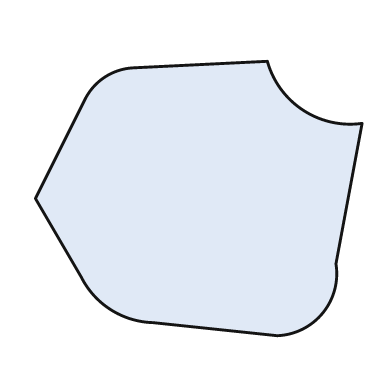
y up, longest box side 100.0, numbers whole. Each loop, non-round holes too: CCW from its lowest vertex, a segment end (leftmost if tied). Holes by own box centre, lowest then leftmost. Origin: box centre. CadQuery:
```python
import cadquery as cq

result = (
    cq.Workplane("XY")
    .moveTo(24.0, -42.0)
    .threePointArc((38.0, -35.0), (42.0, -20.0))
    .lineTo(50.0, 23.0)
    .threePointArc((32.0, 27.0), (21.0, 42.0))
    .lineTo(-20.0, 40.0)
    .threePointArc((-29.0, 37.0), (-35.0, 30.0))
    .lineTo(-50.0, 0.0)
    .lineTo(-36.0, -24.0)
    .threePointArc((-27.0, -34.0), (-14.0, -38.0))
    .close()
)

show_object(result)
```